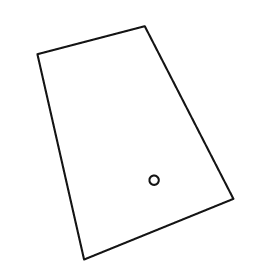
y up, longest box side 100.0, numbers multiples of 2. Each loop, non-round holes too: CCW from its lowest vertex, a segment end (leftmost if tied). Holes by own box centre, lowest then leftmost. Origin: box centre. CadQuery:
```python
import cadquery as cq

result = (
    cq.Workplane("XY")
    .moveTo(-22.0, -50.0)
    .lineTo(42.0, -24.0)
    .lineTo(4.0, 50.0)
    .lineTo(-42.0, 38.0)
    .close()
    .moveTo(8.0, -16.0)
    .circle(2.0)
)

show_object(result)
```